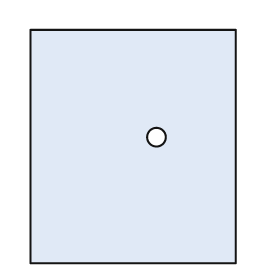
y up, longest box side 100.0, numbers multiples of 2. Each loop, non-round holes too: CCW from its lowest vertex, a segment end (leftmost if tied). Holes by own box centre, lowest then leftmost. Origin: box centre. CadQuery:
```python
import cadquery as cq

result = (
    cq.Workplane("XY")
    .moveTo(-44.0, -50.0)
    .lineTo(44.0, -50.0)
    .lineTo(44.0, 50.0)
    .lineTo(-44.0, 50.0)
    .close()
    .moveTo(10.0, 4.0)
    .circle(4.0)
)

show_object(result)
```